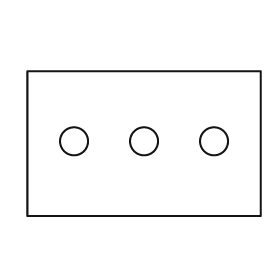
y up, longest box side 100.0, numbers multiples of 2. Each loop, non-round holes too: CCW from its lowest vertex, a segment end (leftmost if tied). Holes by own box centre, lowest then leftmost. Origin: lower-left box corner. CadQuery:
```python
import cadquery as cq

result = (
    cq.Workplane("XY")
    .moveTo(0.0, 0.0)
    .lineTo(100.0, 0.0)
    .lineTo(100.0, 62.0)
    .lineTo(0.0, 62.0)
    .close()
    .moveTo(20.0, 32.0)
    .circle(6.0)
    .moveTo(50.0, 32.0)
    .circle(6.0)
    .moveTo(80.0, 32.0)
    .circle(6.0)
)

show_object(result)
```